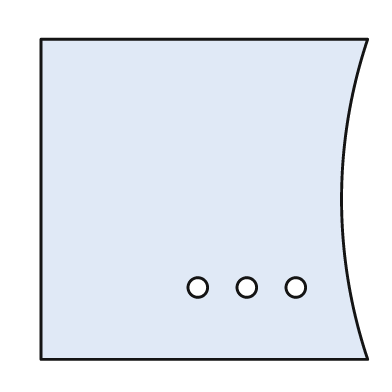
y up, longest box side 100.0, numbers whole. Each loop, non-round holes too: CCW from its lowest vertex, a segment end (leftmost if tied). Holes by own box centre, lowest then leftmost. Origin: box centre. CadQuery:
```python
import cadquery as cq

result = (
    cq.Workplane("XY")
    .moveTo(-50.0, -49.0)
    .lineTo(50.0, -49.0)
    .threePointArc((42.0, 0.0), (50.0, 49.0))
    .lineTo(-50.0, 49.0)
    .close()
    .moveTo(-2.0, -27.0)
    .circle(3.0)
    .moveTo(13.0, -27.0)
    .circle(3.0)
    .moveTo(28.0, -27.0)
    .circle(3.0)
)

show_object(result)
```